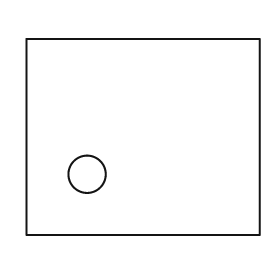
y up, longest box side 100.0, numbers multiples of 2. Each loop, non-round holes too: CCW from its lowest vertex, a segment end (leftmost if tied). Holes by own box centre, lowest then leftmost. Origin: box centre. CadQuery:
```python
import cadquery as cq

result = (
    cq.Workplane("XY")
    .moveTo(-50.0, -42.0)
    .lineTo(50.0, -42.0)
    .lineTo(50.0, 42.0)
    .lineTo(-50.0, 42.0)
    .close()
    .moveTo(-24.0, -16.0)
    .circle(8.0)
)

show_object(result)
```